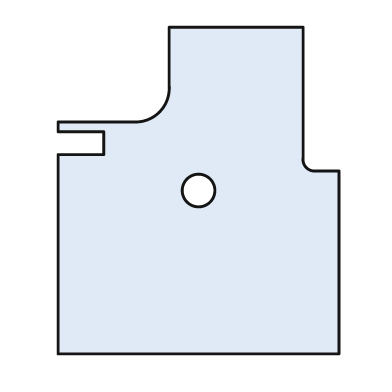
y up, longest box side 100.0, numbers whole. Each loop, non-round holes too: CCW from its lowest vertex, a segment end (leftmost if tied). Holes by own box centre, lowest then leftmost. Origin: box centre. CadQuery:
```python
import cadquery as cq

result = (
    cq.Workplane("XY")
    .moveTo(-43.0, -50.0)
    .lineTo(43.0, -50.0)
    .lineTo(43.0, 6.0)
    .lineTo(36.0, 6.0)
    .threePointArc((33.0, 7.0), (32.0, 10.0))
    .lineTo(32.0, 50.0)
    .lineTo(-9.0, 50.0)
    .lineTo(-9.0, 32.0)
    .threePointArc((-12.0, 24.0), (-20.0, 21.0))
    .lineTo(-43.0, 21.0)
    .lineTo(-43.0, 18.0)
    .lineTo(-29.0, 18.0)
    .lineTo(-29.0, 11.0)
    .lineTo(-43.0, 11.0)
    .close()
    .moveTo(0.0, 0.0)
    .circle(5.0)
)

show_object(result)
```